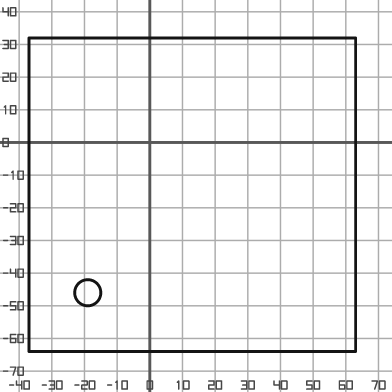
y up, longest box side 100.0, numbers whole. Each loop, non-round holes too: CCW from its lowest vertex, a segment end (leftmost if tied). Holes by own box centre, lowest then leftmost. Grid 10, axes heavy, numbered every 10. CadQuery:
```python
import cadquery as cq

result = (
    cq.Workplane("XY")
    .moveTo(-37.0, -64.0)
    .lineTo(63.0, -64.0)
    .lineTo(63.0, 32.0)
    .lineTo(-37.0, 32.0)
    .close()
    .moveTo(-19.0, -46.0)
    .circle(4.0)
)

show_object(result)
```